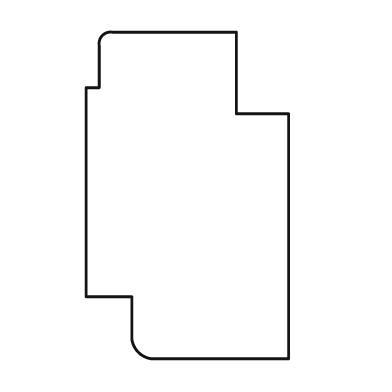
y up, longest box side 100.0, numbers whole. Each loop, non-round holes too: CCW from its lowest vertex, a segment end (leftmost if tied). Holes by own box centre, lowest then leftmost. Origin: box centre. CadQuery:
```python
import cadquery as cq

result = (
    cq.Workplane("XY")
    .moveTo(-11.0, -50.0)
    .lineTo(31.0, -50.0)
    .lineTo(31.0, 25.0)
    .lineTo(15.0, 25.0)
    .lineTo(15.0, 50.0)
    .lineTo(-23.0, 50.0)
    .threePointArc((-26.0, 49.0), (-27.0, 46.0))
    .lineTo(-27.0, 33.0)
    .lineTo(-31.0, 33.0)
    .lineTo(-31.0, -31.0)
    .lineTo(-17.0, -31.0)
    .lineTo(-17.0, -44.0)
    .threePointArc((-15.0, -48.0), (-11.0, -50.0))
    .close()
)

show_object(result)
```